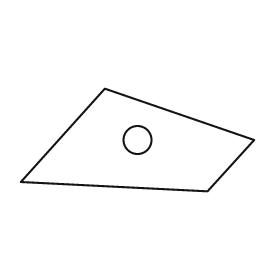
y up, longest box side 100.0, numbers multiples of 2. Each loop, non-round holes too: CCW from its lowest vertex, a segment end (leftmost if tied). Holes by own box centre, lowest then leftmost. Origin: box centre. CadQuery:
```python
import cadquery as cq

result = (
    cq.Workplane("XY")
    .moveTo(30.0, -22.0)
    .lineTo(50.0, 0.0)
    .lineTo(-14.0, 22.0)
    .lineTo(-50.0, -18.0)
    .close()
    .moveTo(0.0, 0.0)
    .circle(6.0)
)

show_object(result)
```